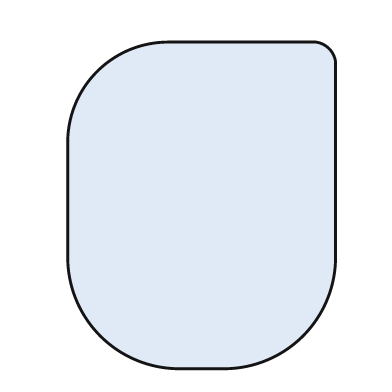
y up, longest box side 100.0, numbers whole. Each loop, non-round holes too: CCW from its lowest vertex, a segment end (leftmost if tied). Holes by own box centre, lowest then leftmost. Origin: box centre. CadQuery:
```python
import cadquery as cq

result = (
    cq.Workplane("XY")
    .moveTo(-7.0, -50.0)
    .lineTo(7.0, -50.0)
    .threePointArc((31.0, -40.0), (41.0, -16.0))
    .lineTo(41.0, 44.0)
    .threePointArc((39.0, 48.0), (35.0, 50.0))
    .lineTo(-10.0, 50.0)
    .threePointArc((-32.0, 41.0), (-41.0, 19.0))
    .lineTo(-41.0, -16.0)
    .threePointArc((-31.0, -40.0), (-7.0, -50.0))
    .close()
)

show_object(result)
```